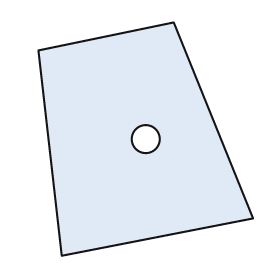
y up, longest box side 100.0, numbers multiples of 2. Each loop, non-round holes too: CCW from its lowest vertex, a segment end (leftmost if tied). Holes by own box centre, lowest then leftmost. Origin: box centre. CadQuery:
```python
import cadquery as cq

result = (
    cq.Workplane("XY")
    .moveTo(-36.0, -50.0)
    .lineTo(46.0, -34.0)
    .lineTo(12.0, 50.0)
    .lineTo(-46.0, 38.0)
    .close()
    .moveTo(0.0, 0.0)
    .circle(6.0)
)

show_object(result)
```